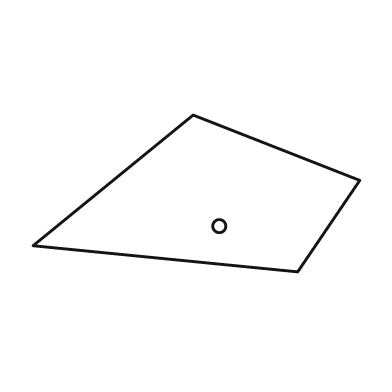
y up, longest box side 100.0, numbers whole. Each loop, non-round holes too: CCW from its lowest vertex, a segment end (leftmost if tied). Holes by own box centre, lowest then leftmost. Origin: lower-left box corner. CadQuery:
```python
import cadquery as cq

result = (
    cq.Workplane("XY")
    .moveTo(81.0, 0.0)
    .lineTo(100.0, 28.0)
    .lineTo(49.0, 48.0)
    .lineTo(0.0, 8.0)
    .close()
    .moveTo(57.0, 14.0)
    .circle(2.0)
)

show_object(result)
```